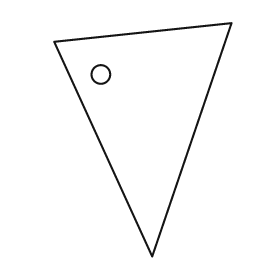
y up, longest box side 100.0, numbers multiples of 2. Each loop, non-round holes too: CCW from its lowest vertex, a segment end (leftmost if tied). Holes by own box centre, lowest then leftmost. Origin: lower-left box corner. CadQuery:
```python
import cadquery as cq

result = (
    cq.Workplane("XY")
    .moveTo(42.0, 0.0)
    .lineTo(76.0, 100.0)
    .lineTo(0.0, 92.0)
    .close()
    .moveTo(20.0, 78.0)
    .circle(4.0)
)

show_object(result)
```